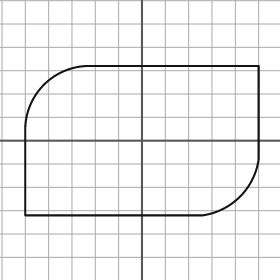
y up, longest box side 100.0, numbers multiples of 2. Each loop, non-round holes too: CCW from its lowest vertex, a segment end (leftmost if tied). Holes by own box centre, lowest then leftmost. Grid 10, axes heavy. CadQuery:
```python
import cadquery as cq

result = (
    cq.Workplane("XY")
    .moveTo(-50.0, -32.0)
    .lineTo(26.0, -32.0)
    .threePointArc((42.0, -24.0), (50.0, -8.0))
    .lineTo(50.0, 32.0)
    .lineTo(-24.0, 32.0)
    .threePointArc((-42.0, 24.0), (-50.0, 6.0))
    .close()
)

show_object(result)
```